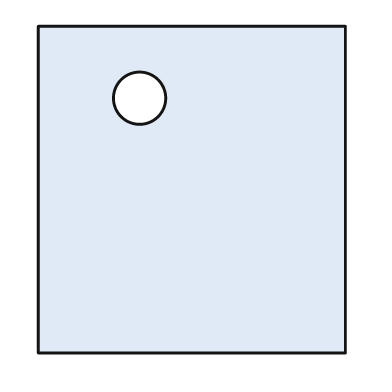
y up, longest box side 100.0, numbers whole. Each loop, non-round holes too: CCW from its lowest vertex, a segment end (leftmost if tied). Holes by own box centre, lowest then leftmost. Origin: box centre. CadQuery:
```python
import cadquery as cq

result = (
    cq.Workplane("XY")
    .moveTo(-47.0, -50.0)
    .lineTo(47.0, -50.0)
    .lineTo(47.0, 50.0)
    .lineTo(-47.0, 50.0)
    .close()
    .moveTo(-16.0, 28.0)
    .circle(8.0)
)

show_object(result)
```